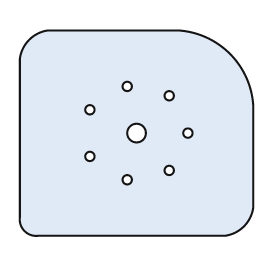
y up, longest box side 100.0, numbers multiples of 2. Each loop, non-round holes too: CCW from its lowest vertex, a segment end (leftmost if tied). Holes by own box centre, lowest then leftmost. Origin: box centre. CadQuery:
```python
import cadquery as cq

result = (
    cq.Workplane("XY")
    .moveTo(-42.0, -44.0)
    .lineTo(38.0, -44.0)
    .threePointArc((46.0, -40.0), (50.0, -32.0))
    .lineTo(50.0, 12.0)
    .threePointArc((40.0, 34.0), (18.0, 44.0))
    .lineTo(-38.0, 44.0)
    .threePointArc((-46.0, 40.0), (-50.0, 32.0))
    .lineTo(-50.0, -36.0)
    .threePointArc((-48.0, -42.0), (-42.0, -44.0))
    .close()
    .moveTo(-4.0, -20.0)
    .circle(2.0)
    .moveTo(14.0, -16.0)
    .circle(2.0)
    .moveTo(-20.0, -10.0)
    .circle(2.0)
    .moveTo(0.0, 0.0)
    .circle(4.0)
    .moveTo(22.0, 0.0)
    .circle(2.0)
    .moveTo(-20.0, 10.0)
    .circle(2.0)
    .moveTo(14.0, 16.0)
    .circle(2.0)
    .moveTo(-4.0, 20.0)
    .circle(2.0)
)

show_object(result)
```